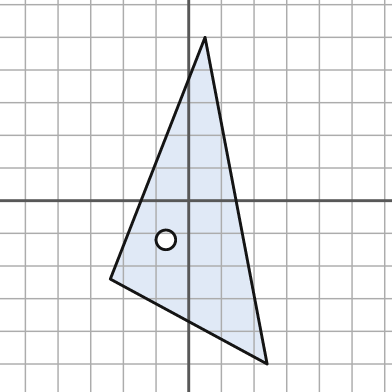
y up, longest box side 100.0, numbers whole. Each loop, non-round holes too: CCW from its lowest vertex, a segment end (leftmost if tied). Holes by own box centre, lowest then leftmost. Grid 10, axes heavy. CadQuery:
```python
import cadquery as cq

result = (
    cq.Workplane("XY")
    .moveTo(24.0, -50.0)
    .lineTo(5.0, 50.0)
    .lineTo(-24.0, -24.0)
    .close()
    .moveTo(-7.0, -12.0)
    .circle(3.0)
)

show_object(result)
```